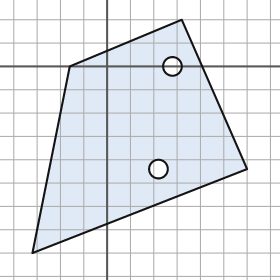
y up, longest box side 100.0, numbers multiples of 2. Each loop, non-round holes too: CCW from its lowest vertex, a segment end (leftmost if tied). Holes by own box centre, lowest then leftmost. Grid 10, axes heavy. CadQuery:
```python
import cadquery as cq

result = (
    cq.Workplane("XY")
    .moveTo(-32.0, -80.0)
    .lineTo(60.0, -44.0)
    .lineTo(32.0, 20.0)
    .lineTo(-16.0, 0.0)
    .close()
    .moveTo(22.0, -44.0)
    .circle(4.0)
    .moveTo(28.0, 0.0)
    .circle(4.0)
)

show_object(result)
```